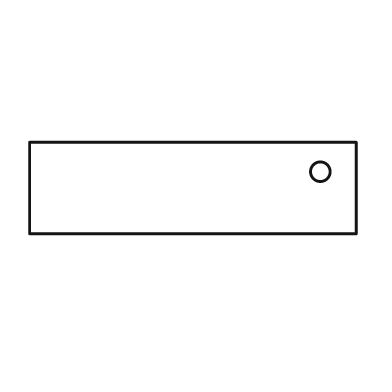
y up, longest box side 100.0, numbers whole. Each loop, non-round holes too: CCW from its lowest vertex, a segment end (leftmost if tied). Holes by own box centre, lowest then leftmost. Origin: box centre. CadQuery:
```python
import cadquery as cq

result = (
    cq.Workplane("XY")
    .moveTo(-50.0, -14.0)
    .lineTo(50.0, -14.0)
    .lineTo(50.0, 14.0)
    .lineTo(-50.0, 14.0)
    .close()
    .moveTo(39.0, 5.0)
    .circle(3.0)
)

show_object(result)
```